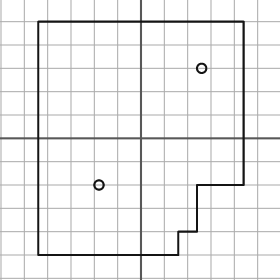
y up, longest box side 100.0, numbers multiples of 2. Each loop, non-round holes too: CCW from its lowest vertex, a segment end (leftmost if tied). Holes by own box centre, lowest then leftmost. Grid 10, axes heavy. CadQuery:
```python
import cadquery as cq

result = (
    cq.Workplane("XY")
    .moveTo(-44.0, -50.0)
    .lineTo(16.0, -50.0)
    .lineTo(16.0, -40.0)
    .lineTo(24.0, -40.0)
    .lineTo(24.0, -20.0)
    .lineTo(44.0, -20.0)
    .lineTo(44.0, 50.0)
    .lineTo(-44.0, 50.0)
    .close()
    .moveTo(-18.0, -20.0)
    .circle(2.0)
    .moveTo(26.0, 30.0)
    .circle(2.0)
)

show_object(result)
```